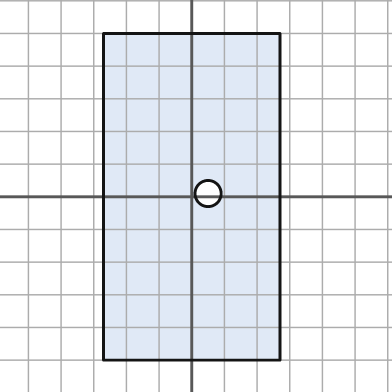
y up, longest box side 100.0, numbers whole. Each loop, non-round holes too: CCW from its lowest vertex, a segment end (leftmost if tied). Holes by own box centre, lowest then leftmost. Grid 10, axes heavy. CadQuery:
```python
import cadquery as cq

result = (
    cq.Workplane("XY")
    .moveTo(-27.0, -50.0)
    .lineTo(27.0, -50.0)
    .lineTo(27.0, 50.0)
    .lineTo(-27.0, 50.0)
    .close()
    .moveTo(5.0, 1.0)
    .circle(4.0)
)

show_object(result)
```